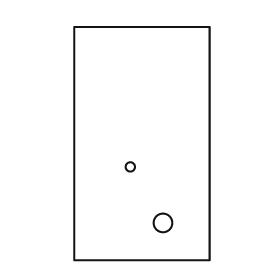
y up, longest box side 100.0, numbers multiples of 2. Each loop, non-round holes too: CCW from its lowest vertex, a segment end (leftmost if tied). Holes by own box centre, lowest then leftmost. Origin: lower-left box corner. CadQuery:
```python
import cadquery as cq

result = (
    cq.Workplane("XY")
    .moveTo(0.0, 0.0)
    .lineTo(58.0, 0.0)
    .lineTo(58.0, 100.0)
    .lineTo(0.0, 100.0)
    .close()
    .moveTo(38.0, 16.0)
    .circle(4.0)
    .moveTo(24.0, 40.0)
    .circle(2.0)
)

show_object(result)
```